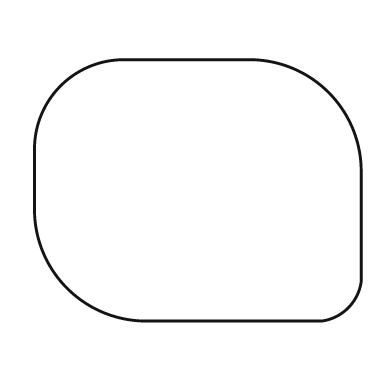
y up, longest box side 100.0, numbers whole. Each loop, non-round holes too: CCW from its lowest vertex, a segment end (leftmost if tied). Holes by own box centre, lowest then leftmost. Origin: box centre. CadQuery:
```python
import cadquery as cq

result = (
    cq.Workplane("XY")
    .moveTo(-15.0, -40.0)
    .lineTo(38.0, -40.0)
    .threePointArc((46.0, -36.0), (50.0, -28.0))
    .lineTo(50.0, 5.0)
    .threePointArc((40.0, 30.0), (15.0, 40.0))
    .lineTo(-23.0, 40.0)
    .threePointArc((-42.0, 32.0), (-50.0, 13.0))
    .lineTo(-50.0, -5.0)
    .threePointArc((-40.0, -30.0), (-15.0, -40.0))
    .close()
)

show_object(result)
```